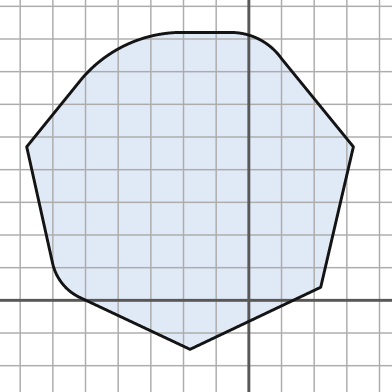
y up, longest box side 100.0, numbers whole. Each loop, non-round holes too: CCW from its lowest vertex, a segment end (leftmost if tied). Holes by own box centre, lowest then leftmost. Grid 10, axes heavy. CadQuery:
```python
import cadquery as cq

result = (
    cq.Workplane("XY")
    .moveTo(-18.0, -15.0)
    .lineTo(22.0, 4.0)
    .lineTo(32.0, 47.0)
    .lineTo(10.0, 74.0)
    .threePointArc((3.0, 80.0), (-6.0, 82.0))
    .lineTo(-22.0, 82.0)
    .threePointArc((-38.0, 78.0), (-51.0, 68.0))
    .lineTo(-68.0, 47.0)
    .lineTo(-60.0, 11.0)
    .threePointArc((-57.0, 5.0), (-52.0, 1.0))
    .close()
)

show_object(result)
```